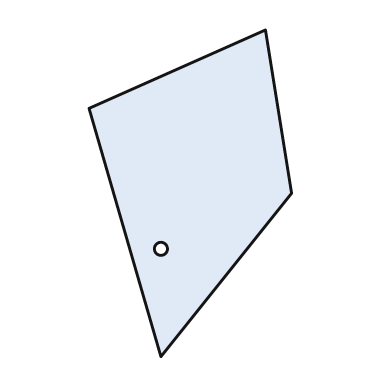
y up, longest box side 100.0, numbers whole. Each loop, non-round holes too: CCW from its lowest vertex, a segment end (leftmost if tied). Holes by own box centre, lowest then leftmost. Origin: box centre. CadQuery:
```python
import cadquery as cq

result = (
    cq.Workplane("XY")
    .moveTo(-9.0, -50.0)
    .lineTo(31.0, 0.0)
    .lineTo(23.0, 50.0)
    .lineTo(-31.0, 26.0)
    .close()
    .moveTo(-9.0, -17.0)
    .circle(2.0)
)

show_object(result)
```